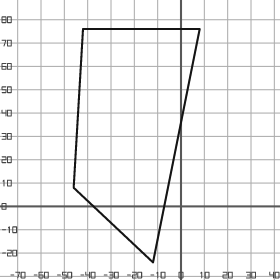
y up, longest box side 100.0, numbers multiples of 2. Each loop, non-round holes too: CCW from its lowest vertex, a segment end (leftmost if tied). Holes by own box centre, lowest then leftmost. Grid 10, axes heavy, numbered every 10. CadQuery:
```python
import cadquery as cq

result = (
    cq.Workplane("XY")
    .moveTo(-12.0, -24.0)
    .lineTo(8.0, 76.0)
    .lineTo(-42.0, 76.0)
    .lineTo(-46.0, 8.0)
    .close()
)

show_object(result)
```